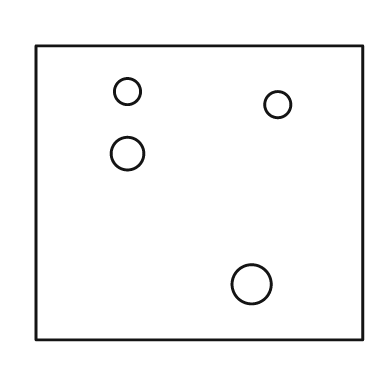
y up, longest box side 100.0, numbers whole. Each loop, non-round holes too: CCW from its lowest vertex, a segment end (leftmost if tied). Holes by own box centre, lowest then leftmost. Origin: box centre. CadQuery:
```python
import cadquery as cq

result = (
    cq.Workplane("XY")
    .moveTo(-50.0, -45.0)
    .lineTo(50.0, -45.0)
    .lineTo(50.0, 45.0)
    .lineTo(-50.0, 45.0)
    .close()
    .moveTo(16.0, -28.0)
    .circle(6.0)
    .moveTo(-22.0, 12.0)
    .circle(5.0)
    .moveTo(24.0, 27.0)
    .circle(4.0)
    .moveTo(-22.0, 31.0)
    .circle(4.0)
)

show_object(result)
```